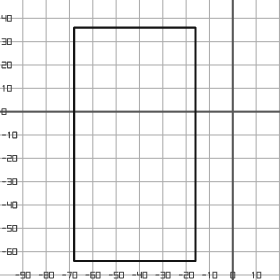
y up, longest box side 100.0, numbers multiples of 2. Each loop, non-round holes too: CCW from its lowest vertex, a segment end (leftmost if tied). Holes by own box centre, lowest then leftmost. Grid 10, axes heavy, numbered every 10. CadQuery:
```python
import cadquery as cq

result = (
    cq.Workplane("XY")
    .moveTo(-68.0, -64.0)
    .lineTo(-16.0, -64.0)
    .lineTo(-16.0, 36.0)
    .lineTo(-68.0, 36.0)
    .close()
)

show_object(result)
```